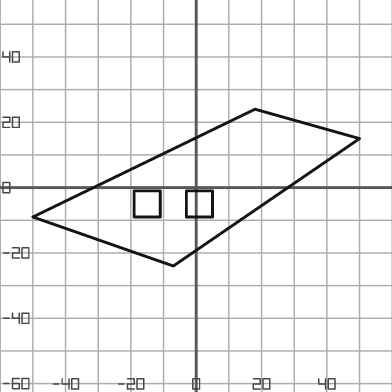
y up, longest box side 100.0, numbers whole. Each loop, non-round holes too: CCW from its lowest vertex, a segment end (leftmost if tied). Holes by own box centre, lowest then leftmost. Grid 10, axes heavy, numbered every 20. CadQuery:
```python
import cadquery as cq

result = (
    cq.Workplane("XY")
    .moveTo(-7.0, -24.0)
    .lineTo(50.0, 15.0)
    .lineTo(18.0, 24.0)
    .lineTo(-50.0, -9.0)
    .close()
    .moveTo(-19.0, -9.0)
    .lineTo(-11.0, -9.0)
    .lineTo(-11.0, -1.0)
    .lineTo(-19.0, -1.0)
    .close()
    .moveTo(-3.0, -9.0)
    .lineTo(5.0, -9.0)
    .lineTo(5.0, -1.0)
    .lineTo(-3.0, -1.0)
    .close()
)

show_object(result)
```